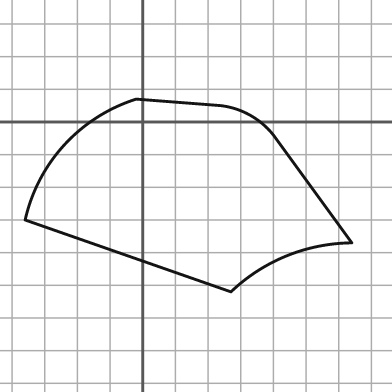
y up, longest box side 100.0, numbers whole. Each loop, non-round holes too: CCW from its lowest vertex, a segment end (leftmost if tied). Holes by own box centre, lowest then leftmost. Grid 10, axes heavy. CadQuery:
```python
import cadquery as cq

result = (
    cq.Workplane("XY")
    .moveTo(27.0, -52.0)
    .threePointArc((44.0, -41.0), (64.0, -37.0))
    .lineTo(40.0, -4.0)
    .threePointArc((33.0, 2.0), (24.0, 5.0))
    .lineTo(-2.0, 7.0)
    .threePointArc((-24.0, -7.0), (-36.0, -30.0))
    .close()
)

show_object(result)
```